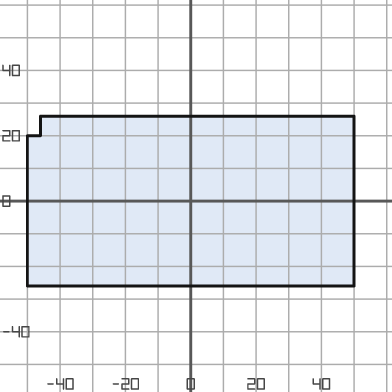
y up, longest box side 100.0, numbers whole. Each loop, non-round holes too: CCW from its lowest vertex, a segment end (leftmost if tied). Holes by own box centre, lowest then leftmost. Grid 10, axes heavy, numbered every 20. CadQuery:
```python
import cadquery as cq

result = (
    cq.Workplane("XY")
    .moveTo(-50.0, -26.0)
    .lineTo(50.0, -26.0)
    .lineTo(50.0, 26.0)
    .lineTo(-46.0, 26.0)
    .lineTo(-46.0, 20.0)
    .lineTo(-50.0, 20.0)
    .close()
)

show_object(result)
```